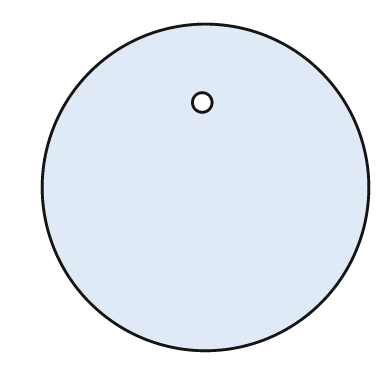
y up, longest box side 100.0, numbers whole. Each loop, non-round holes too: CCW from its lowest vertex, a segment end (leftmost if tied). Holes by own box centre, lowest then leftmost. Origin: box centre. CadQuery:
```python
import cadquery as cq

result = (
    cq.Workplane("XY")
    .moveTo(0.0, 0.0)
    .circle(50.0)
    .moveTo(-1.0, 26.0)
    .circle(3.0)
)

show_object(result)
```